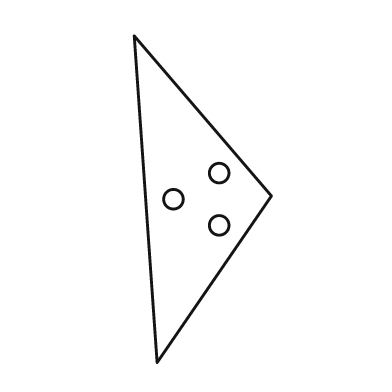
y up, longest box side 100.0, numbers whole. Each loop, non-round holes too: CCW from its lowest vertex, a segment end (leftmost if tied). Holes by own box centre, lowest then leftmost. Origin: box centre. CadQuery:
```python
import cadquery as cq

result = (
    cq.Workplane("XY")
    .moveTo(-14.0, -50.0)
    .lineTo(21.0, 1.0)
    .lineTo(-21.0, 50.0)
    .close()
    .moveTo(5.0, -8.0)
    .circle(3.0)
    .moveTo(-9.0, 0.0)
    .circle(3.0)
    .moveTo(5.0, 8.0)
    .circle(3.0)
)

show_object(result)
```